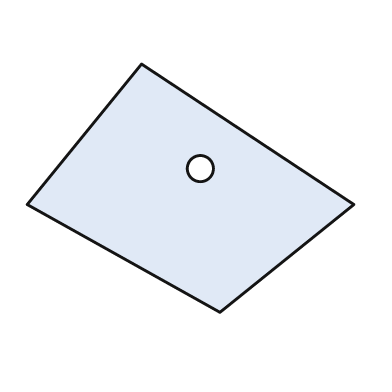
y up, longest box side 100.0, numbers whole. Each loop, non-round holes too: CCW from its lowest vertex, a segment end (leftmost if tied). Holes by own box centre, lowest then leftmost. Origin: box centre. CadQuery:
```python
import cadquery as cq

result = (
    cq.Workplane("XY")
    .moveTo(9.0, -38.0)
    .lineTo(50.0, -5.0)
    .lineTo(-15.0, 38.0)
    .lineTo(-50.0, -5.0)
    .close()
    .moveTo(3.0, 6.0)
    .circle(4.0)
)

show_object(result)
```